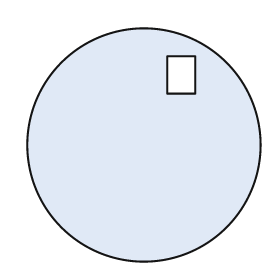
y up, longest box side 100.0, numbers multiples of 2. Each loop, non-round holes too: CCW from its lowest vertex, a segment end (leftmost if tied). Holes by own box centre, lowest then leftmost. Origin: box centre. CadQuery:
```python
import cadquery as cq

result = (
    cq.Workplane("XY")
    .moveTo(0.0, 0.0)
    .circle(50.0)
    .moveTo(10.0, 22.0)
    .lineTo(22.0, 22.0)
    .lineTo(22.0, 38.0)
    .lineTo(10.0, 38.0)
    .close()
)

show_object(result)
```